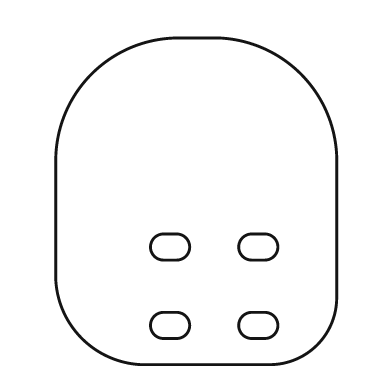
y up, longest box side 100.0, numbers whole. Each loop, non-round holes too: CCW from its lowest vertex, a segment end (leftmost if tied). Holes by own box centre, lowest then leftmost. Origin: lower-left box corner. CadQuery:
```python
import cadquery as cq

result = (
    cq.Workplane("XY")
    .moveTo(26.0, 0.0)
    .lineTo(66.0, 0.0)
    .threePointArc((80.0, 6.0), (86.0, 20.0))
    .lineTo(86.0, 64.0)
    .threePointArc((75.0, 89.0), (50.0, 100.0))
    .lineTo(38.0, 100.0)
    .threePointArc((11.0, 89.0), (0.0, 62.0))
    .lineTo(0.0, 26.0)
    .threePointArc((8.0, 8.0), (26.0, 0.0))
    .close()
    .moveTo(33.0, 8.0)
    .lineTo(37.0, 8.0)
    .threePointArc((41.0, 12.0), (37.0, 16.0))
    .lineTo(33.0, 16.0)
    .threePointArc((29.0, 12.0), (33.0, 8.0))
    .close()
    .moveTo(60.0, 8.0)
    .lineTo(64.0, 8.0)
    .threePointArc((68.0, 12.0), (64.0, 16.0))
    .lineTo(60.0, 16.0)
    .threePointArc((56.0, 12.0), (60.0, 8.0))
    .close()
    .moveTo(33.0, 32.0)
    .lineTo(37.0, 32.0)
    .threePointArc((41.0, 36.0), (37.0, 40.0))
    .lineTo(33.0, 40.0)
    .threePointArc((29.0, 36.0), (33.0, 32.0))
    .close()
    .moveTo(60.0, 32.0)
    .lineTo(64.0, 32.0)
    .threePointArc((68.0, 36.0), (64.0, 40.0))
    .lineTo(60.0, 40.0)
    .threePointArc((56.0, 36.0), (60.0, 32.0))
    .close()
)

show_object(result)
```